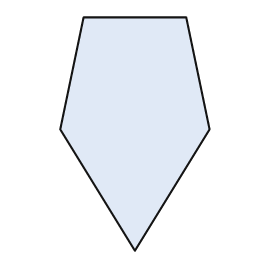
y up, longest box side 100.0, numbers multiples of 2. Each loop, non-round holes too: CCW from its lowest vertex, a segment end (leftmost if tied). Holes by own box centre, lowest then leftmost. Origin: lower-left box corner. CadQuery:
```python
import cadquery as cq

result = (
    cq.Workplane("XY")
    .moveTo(32.0, 0.0)
    .lineTo(64.0, 52.0)
    .lineTo(54.0, 100.0)
    .lineTo(10.0, 100.0)
    .lineTo(0.0, 52.0)
    .close()
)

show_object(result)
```